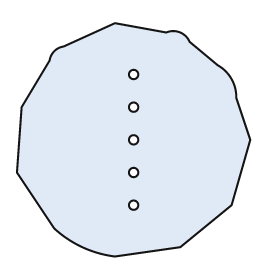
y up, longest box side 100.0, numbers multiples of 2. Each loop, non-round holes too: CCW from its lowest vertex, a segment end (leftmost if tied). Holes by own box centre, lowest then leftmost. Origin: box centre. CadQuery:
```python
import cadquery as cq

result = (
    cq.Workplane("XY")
    .moveTo(-8.0, -50.0)
    .lineTo(20.0, -46.0)
    .lineTo(42.0, -28.0)
    .lineTo(50.0, 0.0)
    .lineTo(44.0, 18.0)
    .threePointArc((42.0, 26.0), (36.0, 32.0))
    .lineTo(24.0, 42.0)
    .threePointArc((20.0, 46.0), (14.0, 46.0))
    .lineTo(-8.0, 50.0)
    .lineTo(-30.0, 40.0)
    .threePointArc((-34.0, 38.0), (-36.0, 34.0))
    .lineTo(-48.0, 14.0)
    .lineTo(-50.0, -14.0)
    .lineTo(-34.0, -38.0)
    .threePointArc((-22.0, -46.0), (-8.0, -50.0))
    .close()
    .moveTo(0.0, -28.0)
    .circle(2.0)
    .moveTo(0.0, -14.0)
    .circle(2.0)
    .moveTo(0.0, 0.0)
    .circle(2.0)
    .moveTo(0.0, 14.0)
    .circle(2.0)
    .moveTo(0.0, 28.0)
    .circle(2.0)
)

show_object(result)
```